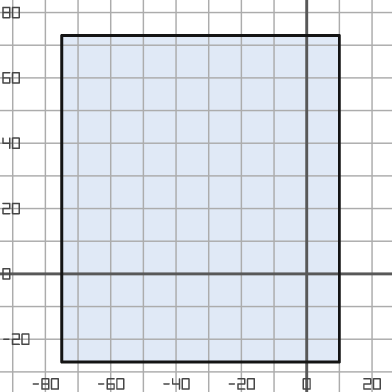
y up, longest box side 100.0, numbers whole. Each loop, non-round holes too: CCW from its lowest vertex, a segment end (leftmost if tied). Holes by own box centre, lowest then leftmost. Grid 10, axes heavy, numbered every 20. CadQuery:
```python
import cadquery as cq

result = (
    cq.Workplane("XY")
    .moveTo(-75.0, -27.0)
    .lineTo(10.0, -27.0)
    .lineTo(10.0, 73.0)
    .lineTo(-75.0, 73.0)
    .close()
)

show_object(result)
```